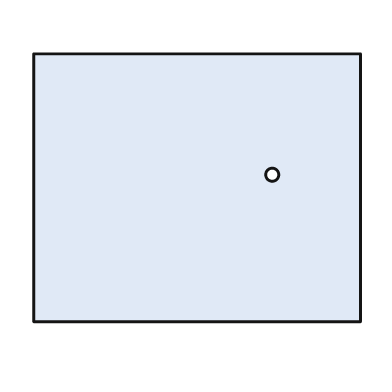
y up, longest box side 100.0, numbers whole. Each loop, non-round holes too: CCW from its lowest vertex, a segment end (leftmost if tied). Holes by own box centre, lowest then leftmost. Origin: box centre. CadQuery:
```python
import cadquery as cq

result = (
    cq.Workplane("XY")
    .moveTo(-50.0, -41.0)
    .lineTo(50.0, -41.0)
    .lineTo(50.0, 41.0)
    .lineTo(-50.0, 41.0)
    .close()
    .moveTo(23.0, 4.0)
    .circle(2.0)
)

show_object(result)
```